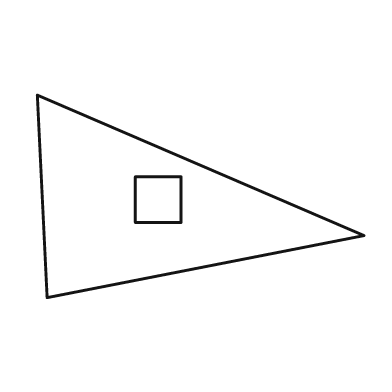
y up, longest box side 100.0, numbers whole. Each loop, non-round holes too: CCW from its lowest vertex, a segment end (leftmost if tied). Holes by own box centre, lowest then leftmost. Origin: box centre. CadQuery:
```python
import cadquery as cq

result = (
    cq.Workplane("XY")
    .moveTo(-47.0, -31.0)
    .lineTo(50.0, -12.0)
    .lineTo(-50.0, 31.0)
    .close()
    .moveTo(-20.0, -8.0)
    .lineTo(-6.0, -8.0)
    .lineTo(-6.0, 6.0)
    .lineTo(-20.0, 6.0)
    .close()
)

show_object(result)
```